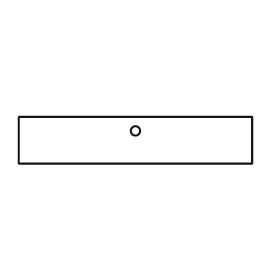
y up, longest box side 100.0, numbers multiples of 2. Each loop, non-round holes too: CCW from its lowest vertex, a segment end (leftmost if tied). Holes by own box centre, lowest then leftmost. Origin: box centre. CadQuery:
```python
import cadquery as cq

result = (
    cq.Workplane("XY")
    .moveTo(-50.0, -10.0)
    .lineTo(50.0, -10.0)
    .lineTo(50.0, 10.0)
    .lineTo(-50.0, 10.0)
    .close()
    .moveTo(0.0, 4.0)
    .circle(2.0)
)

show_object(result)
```